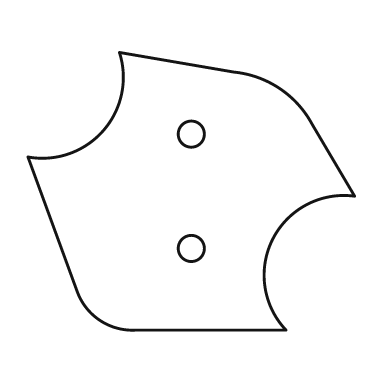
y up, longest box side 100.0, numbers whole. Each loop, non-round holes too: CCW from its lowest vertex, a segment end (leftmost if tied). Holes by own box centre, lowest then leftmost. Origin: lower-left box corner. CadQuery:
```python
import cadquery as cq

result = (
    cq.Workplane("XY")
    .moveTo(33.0, 0.0)
    .lineTo(79.0, 0.0)
    .threePointArc((75.0, 28.0), (100.0, 41.0))
    .lineTo(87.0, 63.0)
    .threePointArc((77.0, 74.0), (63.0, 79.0))
    .lineTo(28.0, 85.0)
    .threePointArc((23.0, 61.0), (0.0, 53.0))
    .lineTo(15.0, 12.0)
    .threePointArc((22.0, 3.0), (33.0, 0.0))
    .close()
    .moveTo(50.0, 25.0)
    .circle(4.0)
    .moveTo(50.0, 60.0)
    .circle(4.0)
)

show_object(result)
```